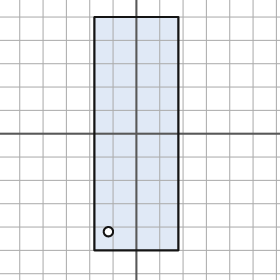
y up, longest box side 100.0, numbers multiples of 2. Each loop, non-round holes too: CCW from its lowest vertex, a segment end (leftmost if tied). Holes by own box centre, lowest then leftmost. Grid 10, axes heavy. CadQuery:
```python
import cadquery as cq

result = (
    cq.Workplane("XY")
    .moveTo(-18.0, -50.0)
    .lineTo(18.0, -50.0)
    .lineTo(18.0, 50.0)
    .lineTo(-18.0, 50.0)
    .close()
    .moveTo(-12.0, -42.0)
    .circle(2.0)
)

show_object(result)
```